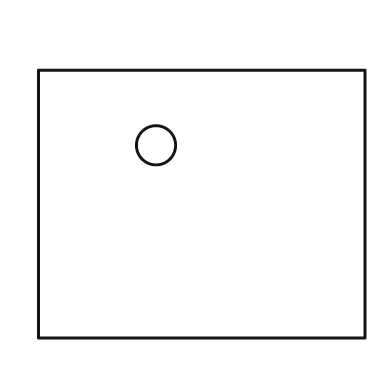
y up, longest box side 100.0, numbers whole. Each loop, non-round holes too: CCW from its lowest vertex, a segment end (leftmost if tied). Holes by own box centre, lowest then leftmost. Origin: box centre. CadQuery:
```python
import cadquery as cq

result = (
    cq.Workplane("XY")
    .moveTo(-50.0, -41.0)
    .lineTo(50.0, -41.0)
    .lineTo(50.0, 41.0)
    .lineTo(-50.0, 41.0)
    .close()
    .moveTo(-14.0, 18.0)
    .circle(6.0)
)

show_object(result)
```